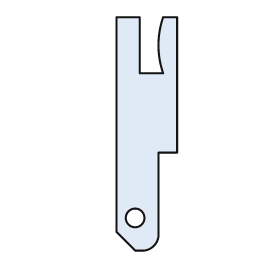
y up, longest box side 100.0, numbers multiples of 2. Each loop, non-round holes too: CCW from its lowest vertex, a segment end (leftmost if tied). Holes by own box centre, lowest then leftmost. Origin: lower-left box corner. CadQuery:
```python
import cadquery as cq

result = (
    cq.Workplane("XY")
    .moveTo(8.0, 0.0)
    .lineTo(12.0, 0.0)
    .threePointArc((16.0, 2.0), (18.0, 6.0))
    .lineTo(18.0, 42.0)
    .lineTo(26.0, 42.0)
    .lineTo(26.0, 100.0)
    .lineTo(20.0, 100.0)
    .threePointArc((18.0, 88.0), (20.0, 76.0))
    .lineTo(10.0, 76.0)
    .lineTo(10.0, 100.0)
    .lineTo(0.0, 100.0)
    .lineTo(0.0, 8.0)
    .close()
    .moveTo(8.0, 14.0)
    .circle(4.0)
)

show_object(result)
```